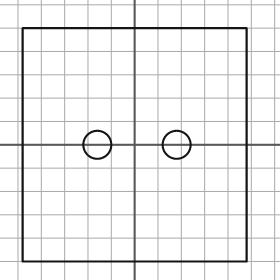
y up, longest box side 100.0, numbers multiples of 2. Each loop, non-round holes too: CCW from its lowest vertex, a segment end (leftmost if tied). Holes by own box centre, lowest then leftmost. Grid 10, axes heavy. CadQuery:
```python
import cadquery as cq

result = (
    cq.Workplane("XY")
    .moveTo(-48.0, -50.0)
    .lineTo(48.0, -50.0)
    .lineTo(48.0, 50.0)
    .lineTo(-48.0, 50.0)
    .close()
    .moveTo(-16.0, 0.0)
    .circle(6.0)
    .moveTo(18.0, 0.0)
    .circle(6.0)
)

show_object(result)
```